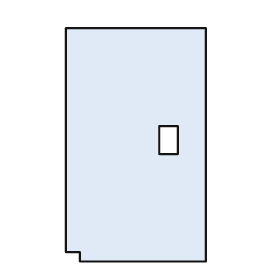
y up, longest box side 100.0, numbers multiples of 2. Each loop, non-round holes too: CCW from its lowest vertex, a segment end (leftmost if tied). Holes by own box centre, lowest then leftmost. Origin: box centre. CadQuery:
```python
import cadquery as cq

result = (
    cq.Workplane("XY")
    .moveTo(-24.0, -50.0)
    .lineTo(30.0, -50.0)
    .lineTo(30.0, 50.0)
    .lineTo(-30.0, 50.0)
    .lineTo(-30.0, -46.0)
    .lineTo(-24.0, -46.0)
    .close()
    .moveTo(10.0, -4.0)
    .lineTo(18.0, -4.0)
    .lineTo(18.0, 8.0)
    .lineTo(10.0, 8.0)
    .close()
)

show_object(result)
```